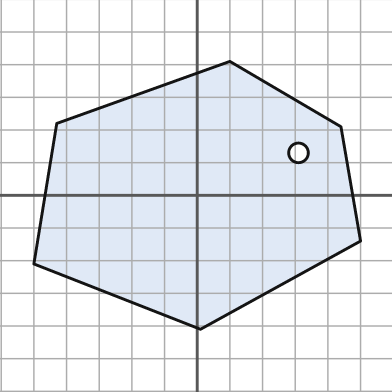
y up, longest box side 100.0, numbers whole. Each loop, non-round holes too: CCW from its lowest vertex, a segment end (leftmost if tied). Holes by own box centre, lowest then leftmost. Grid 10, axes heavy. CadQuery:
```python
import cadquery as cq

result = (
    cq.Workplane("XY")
    .moveTo(1.0, -41.0)
    .lineTo(50.0, -14.0)
    .lineTo(44.0, 21.0)
    .lineTo(10.0, 41.0)
    .lineTo(-43.0, 22.0)
    .lineTo(-50.0, -21.0)
    .close()
    .moveTo(31.0, 13.0)
    .circle(3.0)
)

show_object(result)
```